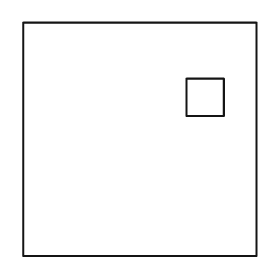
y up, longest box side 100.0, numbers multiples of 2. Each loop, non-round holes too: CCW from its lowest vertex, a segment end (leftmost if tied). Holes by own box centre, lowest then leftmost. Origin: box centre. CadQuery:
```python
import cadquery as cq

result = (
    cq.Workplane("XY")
    .moveTo(-50.0, -50.0)
    .lineTo(50.0, -50.0)
    .lineTo(50.0, 50.0)
    .lineTo(-50.0, 50.0)
    .close()
    .moveTo(20.0, 10.0)
    .lineTo(36.0, 10.0)
    .lineTo(36.0, 26.0)
    .lineTo(20.0, 26.0)
    .close()
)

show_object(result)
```